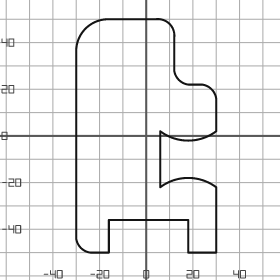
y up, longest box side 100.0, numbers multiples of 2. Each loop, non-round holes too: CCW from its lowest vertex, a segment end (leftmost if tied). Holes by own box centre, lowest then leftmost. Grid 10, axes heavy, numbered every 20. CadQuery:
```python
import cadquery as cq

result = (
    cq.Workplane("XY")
    .moveTo(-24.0, -50.0)
    .lineTo(-16.0, -50.0)
    .lineTo(-16.0, -36.0)
    .lineTo(18.0, -36.0)
    .lineTo(18.0, -50.0)
    .lineTo(30.0, -50.0)
    .lineTo(30.0, -22.0)
    .threePointArc((18.0, -18.0), (6.0, -22.0))
    .lineTo(6.0, 2.0)
    .threePointArc((18.0, -2.0), (30.0, 2.0))
    .lineTo(30.0, 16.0)
    .threePointArc((28.0, 20.0), (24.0, 22.0))
    .lineTo(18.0, 22.0)
    .threePointArc((14.0, 24.0), (12.0, 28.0))
    .lineTo(12.0, 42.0)
    .threePointArc((10.0, 48.0), (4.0, 50.0))
    .lineTo(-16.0, 50.0)
    .threePointArc((-26.0, 46.0), (-30.0, 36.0))
    .lineTo(-30.0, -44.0)
    .threePointArc((-28.0, -48.0), (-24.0, -50.0))
    .close()
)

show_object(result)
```